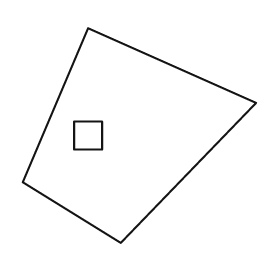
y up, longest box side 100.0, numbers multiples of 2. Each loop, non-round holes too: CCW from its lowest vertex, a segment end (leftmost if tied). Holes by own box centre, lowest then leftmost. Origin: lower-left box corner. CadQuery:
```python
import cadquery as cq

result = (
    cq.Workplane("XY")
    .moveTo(42.0, 0.0)
    .lineTo(100.0, 60.0)
    .lineTo(28.0, 92.0)
    .lineTo(0.0, 26.0)
    .close()
    .moveTo(22.0, 40.0)
    .lineTo(34.0, 40.0)
    .lineTo(34.0, 52.0)
    .lineTo(22.0, 52.0)
    .close()
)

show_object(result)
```